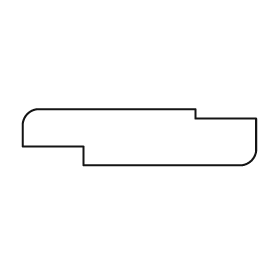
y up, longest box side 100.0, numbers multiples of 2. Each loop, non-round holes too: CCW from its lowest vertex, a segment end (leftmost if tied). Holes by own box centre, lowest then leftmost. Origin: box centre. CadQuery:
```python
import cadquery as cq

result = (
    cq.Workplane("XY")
    .moveTo(-24.0, -12.0)
    .lineTo(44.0, -12.0)
    .threePointArc((48.0, -10.0), (50.0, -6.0))
    .lineTo(50.0, 8.0)
    .lineTo(24.0, 8.0)
    .lineTo(24.0, 12.0)
    .lineTo(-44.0, 12.0)
    .threePointArc((-48.0, 10.0), (-50.0, 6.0))
    .lineTo(-50.0, -4.0)
    .lineTo(-24.0, -4.0)
    .close()
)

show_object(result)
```